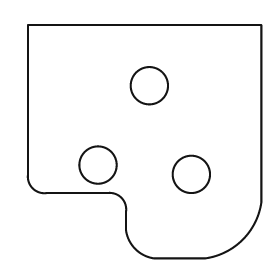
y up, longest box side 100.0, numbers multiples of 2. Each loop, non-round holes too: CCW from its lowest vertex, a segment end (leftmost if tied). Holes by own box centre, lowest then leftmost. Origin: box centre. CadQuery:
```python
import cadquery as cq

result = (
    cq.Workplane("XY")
    .moveTo(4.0, -50.0)
    .lineTo(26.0, -50.0)
    .threePointArc((42.0, -42.0), (50.0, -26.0))
    .lineTo(50.0, 50.0)
    .lineTo(-50.0, 50.0)
    .lineTo(-50.0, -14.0)
    .threePointArc((-48.0, -20.0), (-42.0, -22.0))
    .lineTo(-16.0, -22.0)
    .threePointArc((-10.0, -24.0), (-8.0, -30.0))
    .lineTo(-8.0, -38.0)
    .threePointArc((-4.0, -46.0), (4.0, -50.0))
    .close()
    .moveTo(20.0, -14.0)
    .circle(8.0)
    .moveTo(-20.0, -10.0)
    .circle(8.0)
    .moveTo(2.0, 24.0)
    .circle(8.0)
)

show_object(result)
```